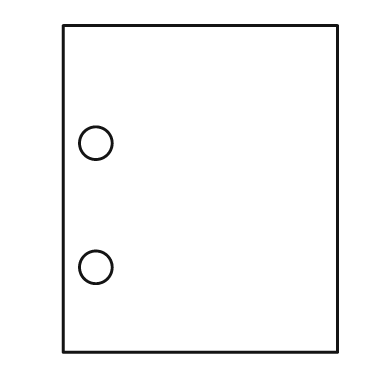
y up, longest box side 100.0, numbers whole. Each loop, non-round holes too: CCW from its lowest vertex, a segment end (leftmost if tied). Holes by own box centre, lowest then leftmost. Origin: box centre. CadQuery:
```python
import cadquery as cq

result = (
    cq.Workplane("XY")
    .moveTo(-42.0, -50.0)
    .lineTo(42.0, -50.0)
    .lineTo(42.0, 50.0)
    .lineTo(-42.0, 50.0)
    .close()
    .moveTo(-32.0, -24.0)
    .circle(5.0)
    .moveTo(-32.0, 14.0)
    .circle(5.0)
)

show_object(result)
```